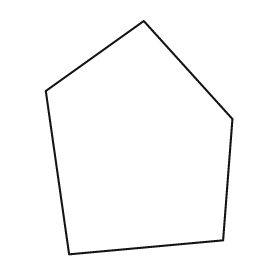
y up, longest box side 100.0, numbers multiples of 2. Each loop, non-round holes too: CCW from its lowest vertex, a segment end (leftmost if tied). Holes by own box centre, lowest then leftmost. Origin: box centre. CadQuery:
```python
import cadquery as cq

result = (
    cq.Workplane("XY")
    .moveTo(-30.0, -50.0)
    .lineTo(36.0, -44.0)
    .lineTo(40.0, 8.0)
    .lineTo(2.0, 50.0)
    .lineTo(-40.0, 20.0)
    .close()
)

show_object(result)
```